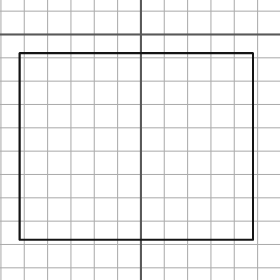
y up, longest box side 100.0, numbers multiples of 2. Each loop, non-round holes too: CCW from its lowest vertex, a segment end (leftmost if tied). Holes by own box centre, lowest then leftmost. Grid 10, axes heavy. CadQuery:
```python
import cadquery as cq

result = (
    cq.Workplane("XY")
    .moveTo(-52.0, -88.0)
    .lineTo(48.0, -88.0)
    .lineTo(48.0, -8.0)
    .lineTo(-52.0, -8.0)
    .close()
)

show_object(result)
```